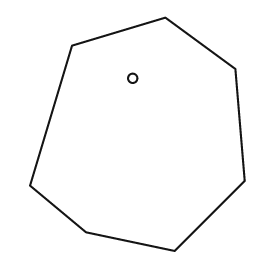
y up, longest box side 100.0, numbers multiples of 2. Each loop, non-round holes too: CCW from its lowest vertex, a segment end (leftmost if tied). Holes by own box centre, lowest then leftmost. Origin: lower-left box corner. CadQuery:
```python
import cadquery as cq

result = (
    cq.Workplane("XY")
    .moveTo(62.0, 0.0)
    .lineTo(92.0, 30.0)
    .lineTo(88.0, 78.0)
    .lineTo(58.0, 100.0)
    .lineTo(18.0, 88.0)
    .lineTo(0.0, 28.0)
    .lineTo(24.0, 8.0)
    .close()
    .moveTo(44.0, 74.0)
    .circle(2.0)
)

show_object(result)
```